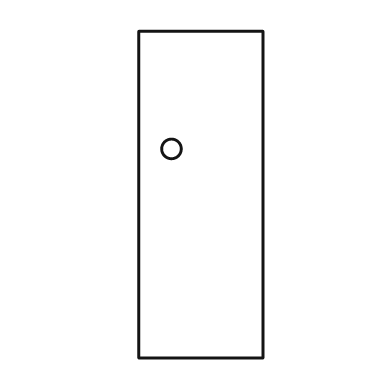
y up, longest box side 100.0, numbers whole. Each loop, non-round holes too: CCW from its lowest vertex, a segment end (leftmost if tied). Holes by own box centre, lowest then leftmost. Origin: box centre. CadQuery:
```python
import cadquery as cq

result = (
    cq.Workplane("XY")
    .moveTo(-19.0, -50.0)
    .lineTo(19.0, -50.0)
    .lineTo(19.0, 50.0)
    .lineTo(-19.0, 50.0)
    .close()
    .moveTo(-9.0, 14.0)
    .circle(3.0)
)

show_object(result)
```